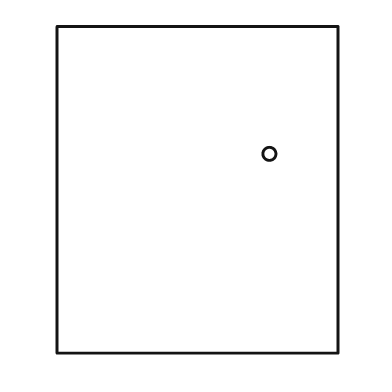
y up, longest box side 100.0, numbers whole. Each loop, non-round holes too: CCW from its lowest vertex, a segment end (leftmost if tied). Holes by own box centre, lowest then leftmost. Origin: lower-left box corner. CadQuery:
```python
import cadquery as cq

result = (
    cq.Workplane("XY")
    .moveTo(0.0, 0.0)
    .lineTo(86.0, 0.0)
    .lineTo(86.0, 100.0)
    .lineTo(0.0, 100.0)
    .close()
    .moveTo(65.0, 61.0)
    .circle(2.0)
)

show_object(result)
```